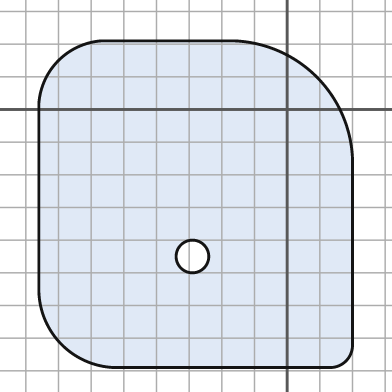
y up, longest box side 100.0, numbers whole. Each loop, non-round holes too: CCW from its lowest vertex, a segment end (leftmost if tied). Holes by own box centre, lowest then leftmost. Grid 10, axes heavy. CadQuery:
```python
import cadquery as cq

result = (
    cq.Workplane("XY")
    .moveTo(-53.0, -79.0)
    .lineTo(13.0, -79.0)
    .threePointArc((18.0, -77.0), (20.0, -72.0))
    .lineTo(20.0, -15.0)
    .threePointArc((9.0, 10.0), (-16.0, 21.0))
    .lineTo(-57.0, 21.0)
    .threePointArc((-70.0, 15.0), (-76.0, 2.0))
    .lineTo(-76.0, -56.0)
    .threePointArc((-69.0, -72.0), (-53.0, -79.0))
    .close()
    .moveTo(-29.0, -45.0)
    .circle(5.0)
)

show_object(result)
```